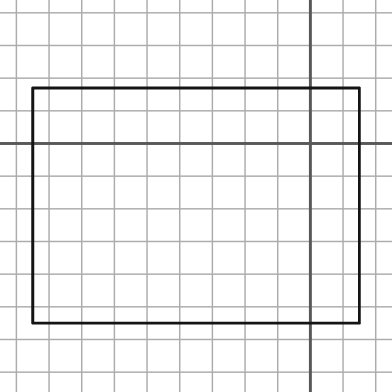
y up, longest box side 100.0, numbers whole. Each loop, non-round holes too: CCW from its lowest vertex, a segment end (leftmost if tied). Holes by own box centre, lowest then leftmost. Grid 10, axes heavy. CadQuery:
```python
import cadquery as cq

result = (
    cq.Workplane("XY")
    .moveTo(-85.0, -55.0)
    .lineTo(15.0, -55.0)
    .lineTo(15.0, 17.0)
    .lineTo(-85.0, 17.0)
    .close()
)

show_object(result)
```